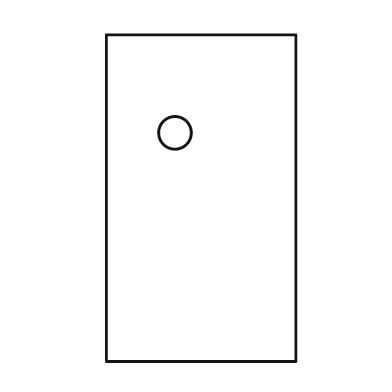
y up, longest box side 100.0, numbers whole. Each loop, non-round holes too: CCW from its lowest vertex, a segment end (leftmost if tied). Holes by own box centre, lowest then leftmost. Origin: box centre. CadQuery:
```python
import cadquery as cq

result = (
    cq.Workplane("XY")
    .moveTo(-29.0, -50.0)
    .lineTo(29.0, -50.0)
    .lineTo(29.0, 50.0)
    .lineTo(-29.0, 50.0)
    .close()
    .moveTo(-8.0, 20.0)
    .circle(5.0)
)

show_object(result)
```